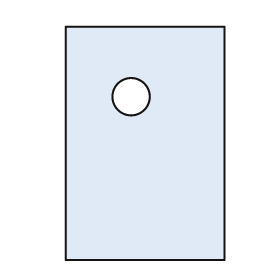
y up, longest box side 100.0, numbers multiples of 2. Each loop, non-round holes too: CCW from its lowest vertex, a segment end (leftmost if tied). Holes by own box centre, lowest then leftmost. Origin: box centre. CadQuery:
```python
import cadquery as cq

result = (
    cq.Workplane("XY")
    .moveTo(-34.0, -50.0)
    .lineTo(34.0, -50.0)
    .lineTo(34.0, 50.0)
    .lineTo(-34.0, 50.0)
    .close()
    .moveTo(-6.0, 20.0)
    .circle(8.0)
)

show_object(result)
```